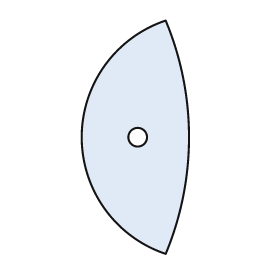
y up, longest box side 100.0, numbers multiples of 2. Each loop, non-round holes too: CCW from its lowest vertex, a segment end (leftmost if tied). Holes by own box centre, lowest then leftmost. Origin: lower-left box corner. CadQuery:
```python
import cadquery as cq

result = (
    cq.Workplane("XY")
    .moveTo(36.0, 0.0)
    .threePointArc((46.0, 50.0), (36.0, 100.0))
    .threePointArc((0.0, 50.0), (36.0, 0.0))
    .close()
    .moveTo(24.0, 50.0)
    .circle(4.0)
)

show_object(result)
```